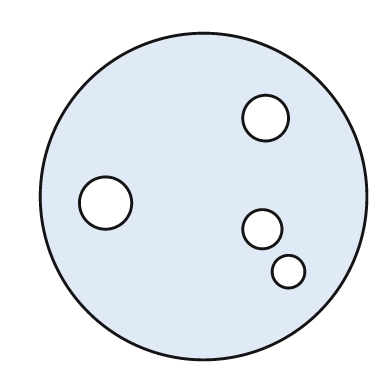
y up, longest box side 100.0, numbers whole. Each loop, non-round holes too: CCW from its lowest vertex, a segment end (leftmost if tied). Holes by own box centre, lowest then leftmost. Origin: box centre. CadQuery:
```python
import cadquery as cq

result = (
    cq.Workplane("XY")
    .moveTo(0.0, 0.0)
    .circle(50.0)
    .moveTo(26.0, -23.0)
    .circle(5.0)
    .moveTo(18.0, -10.0)
    .circle(6.0)
    .moveTo(-30.0, -2.0)
    .circle(8.0)
    .moveTo(19.0, 24.0)
    .circle(7.0)
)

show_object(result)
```